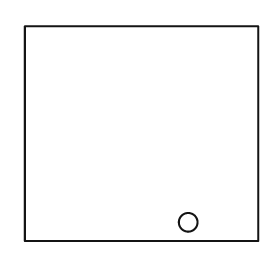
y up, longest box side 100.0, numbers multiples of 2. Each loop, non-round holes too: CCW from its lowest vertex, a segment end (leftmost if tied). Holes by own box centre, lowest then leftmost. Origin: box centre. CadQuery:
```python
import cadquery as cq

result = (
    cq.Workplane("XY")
    .moveTo(-50.0, -46.0)
    .lineTo(50.0, -46.0)
    .lineTo(50.0, 46.0)
    .lineTo(-50.0, 46.0)
    .close()
    .moveTo(20.0, -38.0)
    .circle(4.0)
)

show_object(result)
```